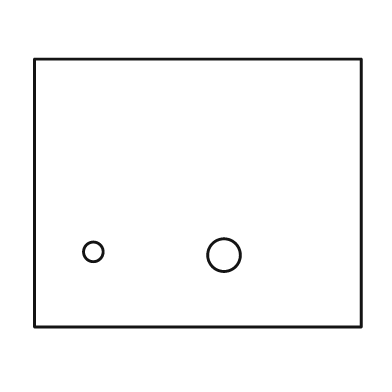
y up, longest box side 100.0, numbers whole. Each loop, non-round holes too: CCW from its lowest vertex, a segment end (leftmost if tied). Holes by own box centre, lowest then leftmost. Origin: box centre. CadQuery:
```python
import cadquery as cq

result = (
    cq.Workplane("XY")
    .moveTo(-50.0, -41.0)
    .lineTo(50.0, -41.0)
    .lineTo(50.0, 41.0)
    .lineTo(-50.0, 41.0)
    .close()
    .moveTo(8.0, -19.0)
    .circle(5.0)
    .moveTo(-32.0, -18.0)
    .circle(3.0)
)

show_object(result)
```